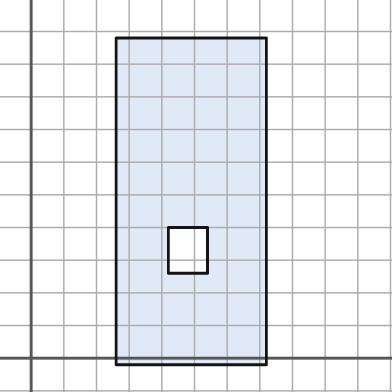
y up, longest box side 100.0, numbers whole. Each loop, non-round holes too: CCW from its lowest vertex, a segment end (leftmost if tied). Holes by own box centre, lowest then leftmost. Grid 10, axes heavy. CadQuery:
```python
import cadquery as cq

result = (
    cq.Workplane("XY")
    .moveTo(26.0, -2.0)
    .lineTo(72.0, -2.0)
    .lineTo(72.0, 98.0)
    .lineTo(26.0, 98.0)
    .close()
    .moveTo(42.0, 26.0)
    .lineTo(54.0, 26.0)
    .lineTo(54.0, 40.0)
    .lineTo(42.0, 40.0)
    .close()
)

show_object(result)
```